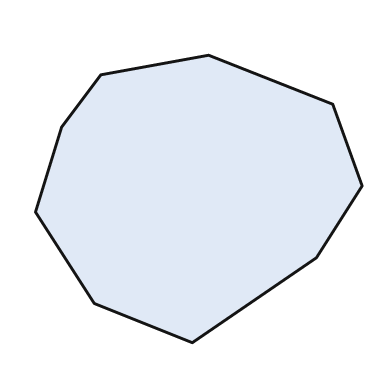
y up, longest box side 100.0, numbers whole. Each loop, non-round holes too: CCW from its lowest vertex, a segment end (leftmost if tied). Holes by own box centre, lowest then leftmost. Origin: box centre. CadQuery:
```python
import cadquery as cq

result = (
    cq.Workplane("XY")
    .moveTo(-2.0, -44.0)
    .lineTo(36.0, -18.0)
    .lineTo(50.0, 4.0)
    .lineTo(41.0, 29.0)
    .lineTo(3.0, 44.0)
    .lineTo(-30.0, 38.0)
    .lineTo(-42.0, 22.0)
    .lineTo(-50.0, -4.0)
    .lineTo(-32.0, -32.0)
    .close()
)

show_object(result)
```